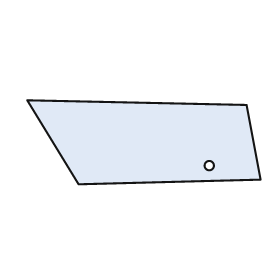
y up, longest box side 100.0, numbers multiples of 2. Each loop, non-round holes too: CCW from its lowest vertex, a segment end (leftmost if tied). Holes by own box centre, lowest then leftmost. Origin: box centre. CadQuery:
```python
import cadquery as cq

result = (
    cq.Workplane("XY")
    .moveTo(-28.0, -18.0)
    .lineTo(50.0, -16.0)
    .lineTo(44.0, 16.0)
    .lineTo(-50.0, 18.0)
    .close()
    .moveTo(28.0, -10.0)
    .circle(2.0)
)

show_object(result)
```